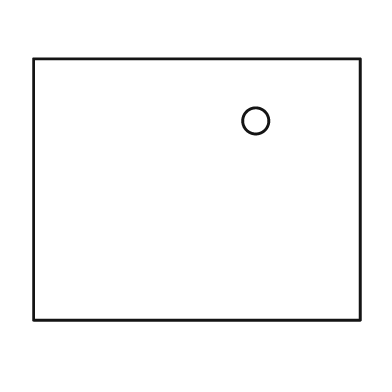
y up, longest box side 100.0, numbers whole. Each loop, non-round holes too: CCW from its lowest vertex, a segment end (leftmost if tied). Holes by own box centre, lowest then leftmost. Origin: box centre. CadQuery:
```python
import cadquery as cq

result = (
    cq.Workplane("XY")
    .moveTo(-50.0, -40.0)
    .lineTo(50.0, -40.0)
    .lineTo(50.0, 40.0)
    .lineTo(-50.0, 40.0)
    .close()
    .moveTo(18.0, 21.0)
    .circle(4.0)
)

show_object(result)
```